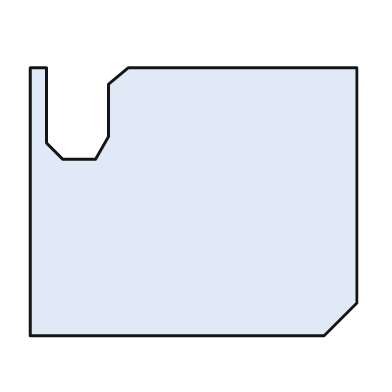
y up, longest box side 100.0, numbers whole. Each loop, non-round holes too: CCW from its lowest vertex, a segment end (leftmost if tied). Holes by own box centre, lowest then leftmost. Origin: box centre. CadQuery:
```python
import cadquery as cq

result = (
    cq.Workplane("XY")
    .moveTo(-50.0, -41.0)
    .lineTo(40.0, -41.0)
    .lineTo(50.0, -31.0)
    .lineTo(50.0, 41.0)
    .lineTo(-20.0, 41.0)
    .lineTo(-26.0, 36.0)
    .lineTo(-26.0, 20.0)
    .lineTo(-30.0, 13.0)
    .lineTo(-40.0, 13.0)
    .lineTo(-45.0, 18.0)
    .lineTo(-45.0, 41.0)
    .lineTo(-50.0, 41.0)
    .close()
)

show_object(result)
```